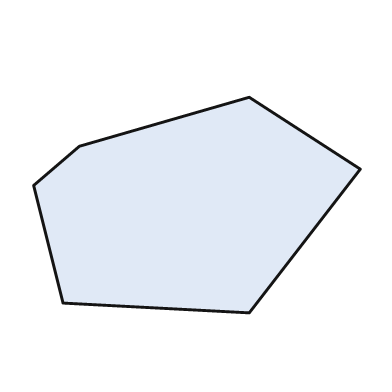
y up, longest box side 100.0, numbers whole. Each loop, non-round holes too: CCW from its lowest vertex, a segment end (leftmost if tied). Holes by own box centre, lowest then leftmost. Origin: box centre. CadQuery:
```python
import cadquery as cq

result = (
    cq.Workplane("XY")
    .moveTo(16.0, -33.0)
    .lineTo(50.0, 11.0)
    .lineTo(16.0, 33.0)
    .lineTo(-36.0, 18.0)
    .lineTo(-50.0, 6.0)
    .lineTo(-41.0, -30.0)
    .close()
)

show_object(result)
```